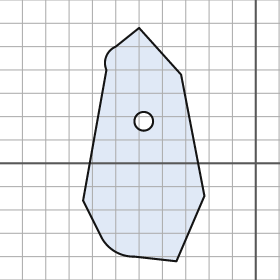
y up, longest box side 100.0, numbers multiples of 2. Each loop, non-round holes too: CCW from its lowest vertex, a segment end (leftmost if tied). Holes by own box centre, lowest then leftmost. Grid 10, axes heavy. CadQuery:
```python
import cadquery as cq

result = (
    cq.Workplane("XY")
    .moveTo(-34.0, -42.0)
    .lineTo(-22.0, -14.0)
    .lineTo(-32.0, 38.0)
    .lineTo(-50.0, 58.0)
    .lineTo(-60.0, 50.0)
    .threePointArc((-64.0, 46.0), (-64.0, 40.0))
    .lineTo(-74.0, -16.0)
    .lineTo(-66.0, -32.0)
    .threePointArc((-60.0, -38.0), (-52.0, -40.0))
    .close()
    .moveTo(-48.0, 18.0)
    .circle(4.0)
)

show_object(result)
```